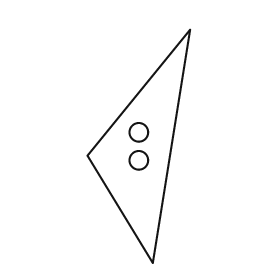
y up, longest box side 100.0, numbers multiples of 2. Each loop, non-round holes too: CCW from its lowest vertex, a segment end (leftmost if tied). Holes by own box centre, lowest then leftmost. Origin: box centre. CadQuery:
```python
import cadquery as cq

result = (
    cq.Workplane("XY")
    .moveTo(6.0, -50.0)
    .lineTo(22.0, 50.0)
    .lineTo(-22.0, -4.0)
    .close()
    .moveTo(0.0, -6.0)
    .circle(4.0)
    .moveTo(0.0, 6.0)
    .circle(4.0)
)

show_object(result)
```